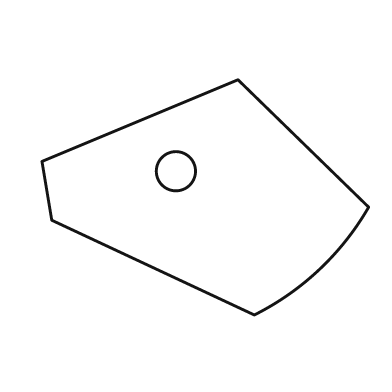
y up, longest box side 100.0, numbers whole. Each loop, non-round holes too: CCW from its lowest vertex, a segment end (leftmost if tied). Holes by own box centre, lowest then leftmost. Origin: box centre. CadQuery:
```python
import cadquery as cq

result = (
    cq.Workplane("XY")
    .moveTo(15.0, -36.0)
    .threePointArc((35.0, -22.0), (50.0, -3.0))
    .lineTo(10.0, 36.0)
    .lineTo(-50.0, 11.0)
    .lineTo(-47.0, -7.0)
    .close()
    .moveTo(-9.0, 8.0)
    .circle(6.0)
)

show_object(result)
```